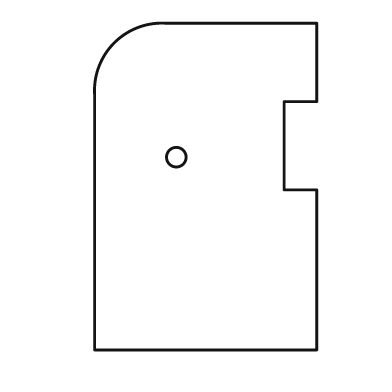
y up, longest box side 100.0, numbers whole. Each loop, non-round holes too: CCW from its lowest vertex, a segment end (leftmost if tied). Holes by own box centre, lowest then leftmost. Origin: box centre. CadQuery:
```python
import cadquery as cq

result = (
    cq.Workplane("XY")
    .moveTo(-34.0, -50.0)
    .lineTo(34.0, -50.0)
    .lineTo(34.0, -1.0)
    .lineTo(24.0, -1.0)
    .lineTo(24.0, 26.0)
    .lineTo(34.0, 26.0)
    .lineTo(34.0, 50.0)
    .lineTo(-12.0, 50.0)
    .threePointArc((-28.0, 44.0), (-34.0, 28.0))
    .close()
    .moveTo(-9.0, 9.0)
    .circle(3.0)
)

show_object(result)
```